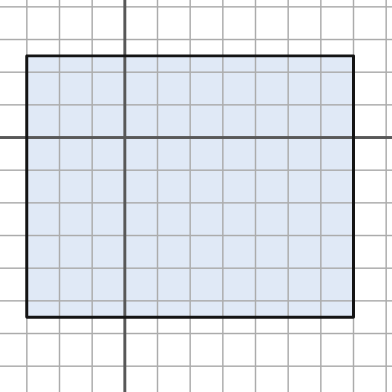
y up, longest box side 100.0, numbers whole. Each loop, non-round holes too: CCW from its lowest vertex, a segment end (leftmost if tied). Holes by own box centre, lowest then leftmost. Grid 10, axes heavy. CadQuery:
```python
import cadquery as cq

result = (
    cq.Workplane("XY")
    .moveTo(-30.0, -55.0)
    .lineTo(70.0, -55.0)
    .lineTo(70.0, 25.0)
    .lineTo(-30.0, 25.0)
    .close()
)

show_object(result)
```